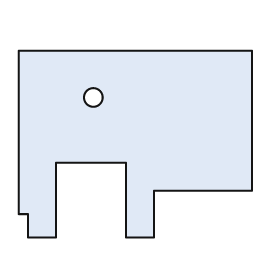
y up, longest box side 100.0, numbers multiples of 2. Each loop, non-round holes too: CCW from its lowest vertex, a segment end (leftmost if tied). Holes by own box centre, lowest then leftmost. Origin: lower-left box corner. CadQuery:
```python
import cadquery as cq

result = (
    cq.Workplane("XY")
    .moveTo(4.0, 0.0)
    .lineTo(16.0, 0.0)
    .lineTo(16.0, 32.0)
    .lineTo(46.0, 32.0)
    .lineTo(46.0, 0.0)
    .lineTo(58.0, 0.0)
    .lineTo(58.0, 20.0)
    .lineTo(100.0, 20.0)
    .lineTo(100.0, 80.0)
    .lineTo(0.0, 80.0)
    .lineTo(0.0, 10.0)
    .lineTo(4.0, 10.0)
    .close()
    .moveTo(32.0, 60.0)
    .circle(4.0)
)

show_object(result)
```